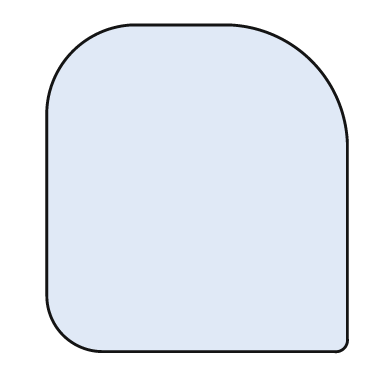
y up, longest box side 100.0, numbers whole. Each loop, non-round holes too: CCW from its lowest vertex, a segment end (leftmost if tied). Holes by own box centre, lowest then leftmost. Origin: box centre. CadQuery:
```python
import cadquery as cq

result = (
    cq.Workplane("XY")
    .moveTo(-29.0, -50.0)
    .lineTo(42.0, -50.0)
    .threePointArc((45.0, -49.0), (46.0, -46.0))
    .lineTo(46.0, 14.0)
    .threePointArc((35.0, 39.0), (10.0, 50.0))
    .lineTo(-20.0, 50.0)
    .threePointArc((-38.0, 42.0), (-46.0, 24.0))
    .lineTo(-46.0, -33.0)
    .threePointArc((-41.0, -45.0), (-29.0, -50.0))
    .close()
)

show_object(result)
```